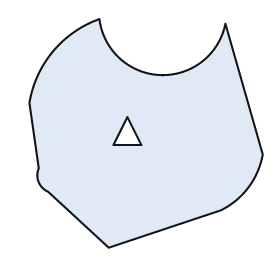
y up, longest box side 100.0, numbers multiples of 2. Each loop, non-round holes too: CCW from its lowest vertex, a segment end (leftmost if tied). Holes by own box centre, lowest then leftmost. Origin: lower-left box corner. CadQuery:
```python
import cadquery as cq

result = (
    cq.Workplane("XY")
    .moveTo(34.0, 0.0)
    .lineTo(82.0, 16.0)
    .threePointArc((94.0, 26.0), (100.0, 40.0))
    .lineTo(84.0, 96.0)
    .threePointArc((56.0, 74.0), (30.0, 98.0))
    .threePointArc((10.0, 84.0), (0.0, 62.0))
    .lineTo(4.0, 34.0)
    .threePointArc((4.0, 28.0), (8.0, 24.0))
    .close()
    .moveTo(36.0, 44.0)
    .lineTo(48.0, 44.0)
    .lineTo(42.0, 56.0)
    .close()
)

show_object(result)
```